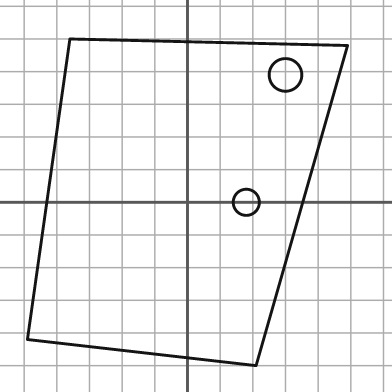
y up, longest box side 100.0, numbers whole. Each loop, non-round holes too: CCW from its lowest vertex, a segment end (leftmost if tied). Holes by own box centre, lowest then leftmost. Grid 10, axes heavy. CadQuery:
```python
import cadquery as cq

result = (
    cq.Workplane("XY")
    .moveTo(21.0, -50.0)
    .lineTo(49.0, 48.0)
    .lineTo(-36.0, 50.0)
    .lineTo(-49.0, -42.0)
    .close()
    .moveTo(18.0, 0.0)
    .circle(4.0)
    .moveTo(30.0, 39.0)
    .circle(5.0)
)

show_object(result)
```